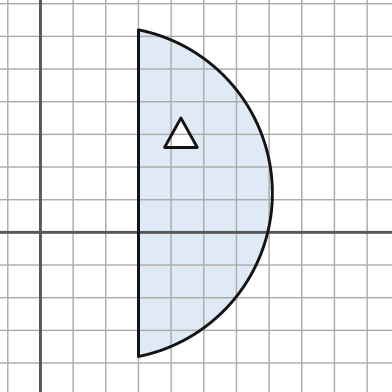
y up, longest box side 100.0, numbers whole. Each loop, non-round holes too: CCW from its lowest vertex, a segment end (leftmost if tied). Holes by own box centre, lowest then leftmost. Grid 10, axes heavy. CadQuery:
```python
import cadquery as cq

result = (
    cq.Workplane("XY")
    .moveTo(30.0, -38.0)
    .threePointArc((71.0, 12.0), (30.0, 62.0))
    .close()
    .moveTo(38.0, 26.0)
    .lineTo(48.0, 26.0)
    .lineTo(43.0, 35.0)
    .close()
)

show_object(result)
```